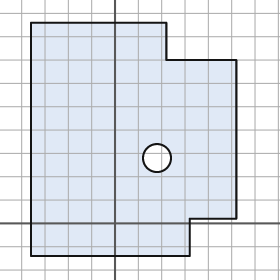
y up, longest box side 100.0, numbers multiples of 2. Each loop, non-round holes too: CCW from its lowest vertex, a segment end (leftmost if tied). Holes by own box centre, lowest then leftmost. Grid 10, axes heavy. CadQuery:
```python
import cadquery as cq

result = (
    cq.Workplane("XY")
    .moveTo(-36.0, -14.0)
    .lineTo(32.0, -14.0)
    .lineTo(32.0, 2.0)
    .lineTo(52.0, 2.0)
    .lineTo(52.0, 70.0)
    .lineTo(22.0, 70.0)
    .lineTo(22.0, 86.0)
    .lineTo(-36.0, 86.0)
    .close()
    .moveTo(18.0, 28.0)
    .circle(6.0)
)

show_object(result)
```